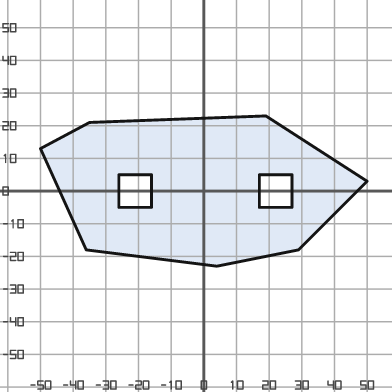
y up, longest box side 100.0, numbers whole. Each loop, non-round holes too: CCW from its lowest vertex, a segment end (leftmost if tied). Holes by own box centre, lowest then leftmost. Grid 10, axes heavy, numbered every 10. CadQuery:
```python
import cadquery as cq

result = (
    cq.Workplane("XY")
    .moveTo(4.0, -23.0)
    .lineTo(29.0, -18.0)
    .lineTo(50.0, 3.0)
    .lineTo(19.0, 23.0)
    .lineTo(-35.0, 21.0)
    .lineTo(-50.0, 13.0)
    .lineTo(-36.0, -18.0)
    .close()
    .moveTo(-26.0, -5.0)
    .lineTo(-16.0, -5.0)
    .lineTo(-16.0, 5.0)
    .lineTo(-26.0, 5.0)
    .close()
    .moveTo(17.0, -5.0)
    .lineTo(27.0, -5.0)
    .lineTo(27.0, 5.0)
    .lineTo(17.0, 5.0)
    .close()
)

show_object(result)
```